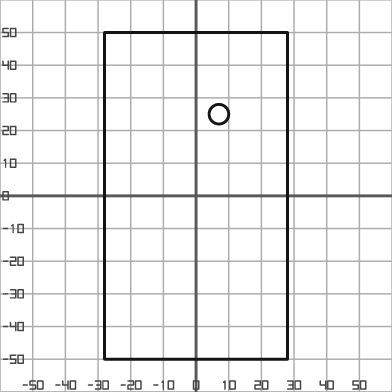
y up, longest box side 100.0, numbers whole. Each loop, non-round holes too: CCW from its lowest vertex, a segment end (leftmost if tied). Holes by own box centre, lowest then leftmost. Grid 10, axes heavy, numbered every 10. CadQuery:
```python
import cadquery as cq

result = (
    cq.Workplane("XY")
    .moveTo(-28.0, -50.0)
    .lineTo(28.0, -50.0)
    .lineTo(28.0, 50.0)
    .lineTo(-28.0, 50.0)
    .close()
    .moveTo(7.0, 25.0)
    .circle(3.0)
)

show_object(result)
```